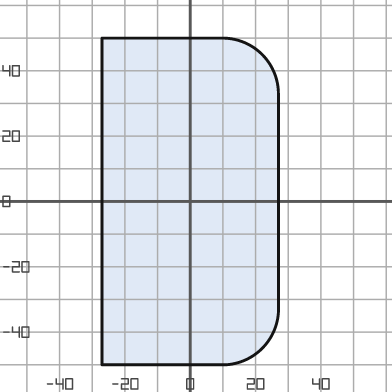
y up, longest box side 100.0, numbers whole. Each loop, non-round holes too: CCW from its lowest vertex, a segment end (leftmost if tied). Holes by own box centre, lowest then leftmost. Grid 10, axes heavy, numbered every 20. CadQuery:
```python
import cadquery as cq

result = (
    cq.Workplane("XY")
    .moveTo(-27.0, -50.0)
    .lineTo(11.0, -50.0)
    .threePointArc((22.0, -45.0), (27.0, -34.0))
    .lineTo(27.0, 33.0)
    .threePointArc((22.0, 45.0), (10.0, 50.0))
    .lineTo(-27.0, 50.0)
    .close()
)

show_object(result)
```